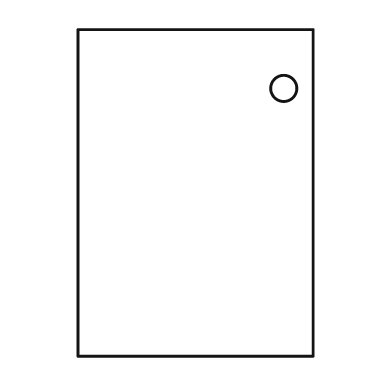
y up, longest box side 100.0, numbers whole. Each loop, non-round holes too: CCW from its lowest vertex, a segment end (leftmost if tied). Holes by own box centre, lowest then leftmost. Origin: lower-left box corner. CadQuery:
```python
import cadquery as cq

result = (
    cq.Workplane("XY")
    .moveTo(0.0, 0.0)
    .lineTo(72.0, 0.0)
    .lineTo(72.0, 100.0)
    .lineTo(0.0, 100.0)
    .close()
    .moveTo(63.0, 82.0)
    .circle(4.0)
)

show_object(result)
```